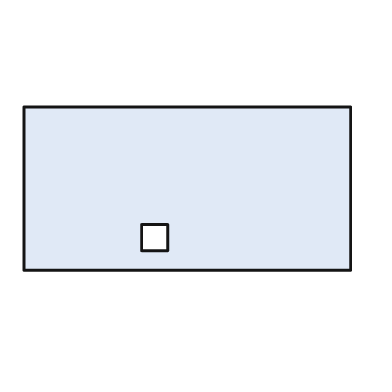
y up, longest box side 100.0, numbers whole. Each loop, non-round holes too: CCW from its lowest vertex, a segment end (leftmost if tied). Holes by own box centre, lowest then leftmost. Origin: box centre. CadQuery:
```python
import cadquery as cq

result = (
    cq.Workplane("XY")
    .moveTo(-50.0, -25.0)
    .lineTo(50.0, -25.0)
    .lineTo(50.0, 25.0)
    .lineTo(-50.0, 25.0)
    .close()
    .moveTo(-14.0, -19.0)
    .lineTo(-6.0, -19.0)
    .lineTo(-6.0, -11.0)
    .lineTo(-14.0, -11.0)
    .close()
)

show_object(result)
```